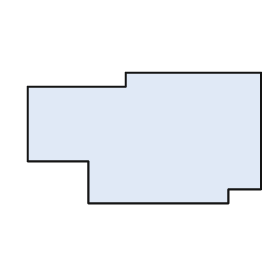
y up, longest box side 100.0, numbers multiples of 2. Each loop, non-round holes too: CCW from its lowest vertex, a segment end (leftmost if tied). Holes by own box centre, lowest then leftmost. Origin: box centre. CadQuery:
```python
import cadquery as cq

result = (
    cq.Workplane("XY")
    .moveTo(-24.0, -28.0)
    .lineTo(36.0, -28.0)
    .lineTo(36.0, -22.0)
    .lineTo(50.0, -22.0)
    .lineTo(50.0, 28.0)
    .lineTo(-8.0, 28.0)
    .lineTo(-8.0, 22.0)
    .lineTo(-50.0, 22.0)
    .lineTo(-50.0, -10.0)
    .lineTo(-24.0, -10.0)
    .close()
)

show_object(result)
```